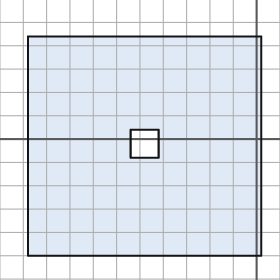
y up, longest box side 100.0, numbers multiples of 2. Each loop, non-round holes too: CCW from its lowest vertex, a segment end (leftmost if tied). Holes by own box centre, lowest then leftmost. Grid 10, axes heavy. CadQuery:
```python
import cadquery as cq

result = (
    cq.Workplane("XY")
    .moveTo(-98.0, -50.0)
    .lineTo(2.0, -50.0)
    .lineTo(2.0, 44.0)
    .lineTo(-98.0, 44.0)
    .close()
    .moveTo(-54.0, -8.0)
    .lineTo(-42.0, -8.0)
    .lineTo(-42.0, 4.0)
    .lineTo(-54.0, 4.0)
    .close()
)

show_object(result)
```